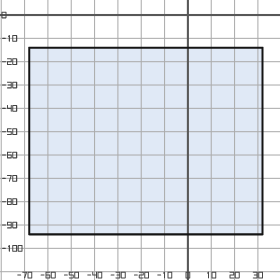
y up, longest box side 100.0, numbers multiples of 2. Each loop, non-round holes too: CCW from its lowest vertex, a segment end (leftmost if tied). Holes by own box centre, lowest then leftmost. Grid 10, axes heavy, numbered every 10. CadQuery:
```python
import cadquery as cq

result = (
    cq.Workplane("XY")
    .moveTo(-68.0, -94.0)
    .lineTo(32.0, -94.0)
    .lineTo(32.0, -14.0)
    .lineTo(-68.0, -14.0)
    .close()
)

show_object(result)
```